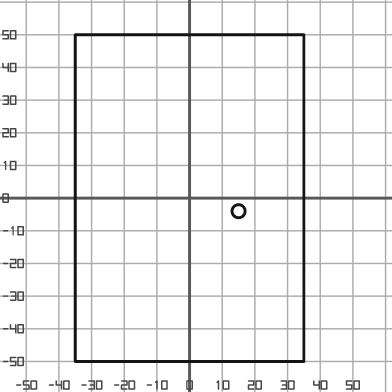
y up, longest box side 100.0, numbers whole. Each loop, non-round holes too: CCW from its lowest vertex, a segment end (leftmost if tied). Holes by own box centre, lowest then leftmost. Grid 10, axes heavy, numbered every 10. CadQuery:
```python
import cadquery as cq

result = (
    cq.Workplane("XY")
    .moveTo(-35.0, -50.0)
    .lineTo(35.0, -50.0)
    .lineTo(35.0, 50.0)
    .lineTo(-35.0, 50.0)
    .close()
    .moveTo(15.0, -4.0)
    .circle(2.0)
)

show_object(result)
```